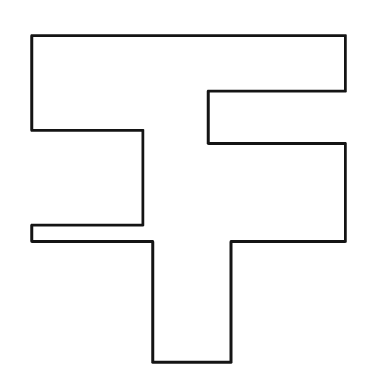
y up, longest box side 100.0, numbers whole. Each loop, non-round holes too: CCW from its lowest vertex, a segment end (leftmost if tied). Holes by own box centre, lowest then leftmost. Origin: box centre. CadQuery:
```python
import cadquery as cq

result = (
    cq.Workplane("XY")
    .moveTo(-11.0, -50.0)
    .lineTo(13.0, -50.0)
    .lineTo(13.0, -13.0)
    .lineTo(48.0, -13.0)
    .lineTo(48.0, 17.0)
    .lineTo(6.0, 17.0)
    .lineTo(6.0, 33.0)
    .lineTo(48.0, 33.0)
    .lineTo(48.0, 50.0)
    .lineTo(-48.0, 50.0)
    .lineTo(-48.0, 21.0)
    .lineTo(-14.0, 21.0)
    .lineTo(-14.0, -8.0)
    .lineTo(-48.0, -8.0)
    .lineTo(-48.0, -13.0)
    .lineTo(-11.0, -13.0)
    .close()
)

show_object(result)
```